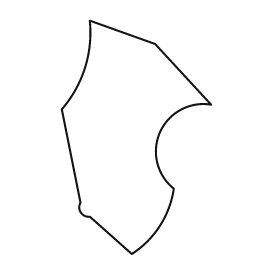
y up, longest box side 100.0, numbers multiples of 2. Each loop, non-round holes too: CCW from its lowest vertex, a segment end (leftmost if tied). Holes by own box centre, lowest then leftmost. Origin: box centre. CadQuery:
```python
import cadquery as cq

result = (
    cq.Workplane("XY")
    .moveTo(-2.0, -50.0)
    .threePointArc((10.0, -38.0), (16.0, -22.0))
    .threePointArc((10.0, 2.0), (32.0, 14.0))
    .lineTo(8.0, 40.0)
    .lineTo(-20.0, 50.0)
    .threePointArc((-22.0, 30.0), (-32.0, 12.0))
    .lineTo(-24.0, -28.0)
    .threePointArc((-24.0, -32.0), (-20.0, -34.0))
    .close()
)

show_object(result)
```